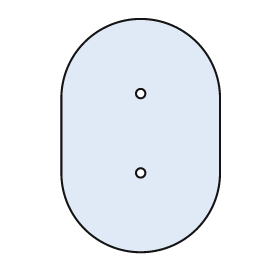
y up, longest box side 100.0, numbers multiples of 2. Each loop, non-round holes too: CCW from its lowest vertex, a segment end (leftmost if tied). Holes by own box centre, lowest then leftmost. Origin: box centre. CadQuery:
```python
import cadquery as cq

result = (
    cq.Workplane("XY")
    .moveTo(-34.0, -16.0)
    .threePointArc((0.0, -50.0), (34.0, -16.0))
    .lineTo(34.0, 16.0)
    .threePointArc((0.0, 50.0), (-34.0, 16.0))
    .close()
    .moveTo(0.0, -16.0)
    .circle(2.0)
    .moveTo(0.0, 18.0)
    .circle(2.0)
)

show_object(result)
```